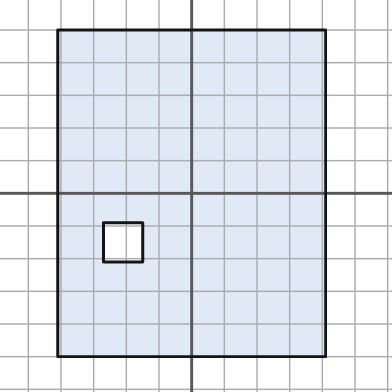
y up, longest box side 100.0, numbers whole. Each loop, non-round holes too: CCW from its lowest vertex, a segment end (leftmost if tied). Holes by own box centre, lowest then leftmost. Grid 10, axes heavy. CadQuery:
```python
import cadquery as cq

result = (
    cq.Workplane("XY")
    .moveTo(-41.0, -50.0)
    .lineTo(41.0, -50.0)
    .lineTo(41.0, 50.0)
    .lineTo(-41.0, 50.0)
    .close()
    .moveTo(-27.0, -21.0)
    .lineTo(-15.0, -21.0)
    .lineTo(-15.0, -9.0)
    .lineTo(-27.0, -9.0)
    .close()
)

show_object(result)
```